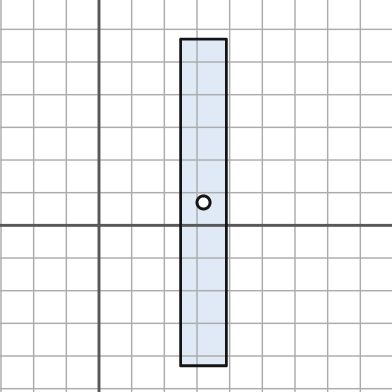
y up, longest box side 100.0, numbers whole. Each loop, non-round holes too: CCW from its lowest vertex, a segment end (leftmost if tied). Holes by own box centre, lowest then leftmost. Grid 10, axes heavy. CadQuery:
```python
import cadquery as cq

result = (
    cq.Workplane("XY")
    .moveTo(25.0, -43.0)
    .lineTo(39.0, -43.0)
    .lineTo(39.0, 57.0)
    .lineTo(25.0, 57.0)
    .close()
    .moveTo(32.0, 7.0)
    .circle(2.0)
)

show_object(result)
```